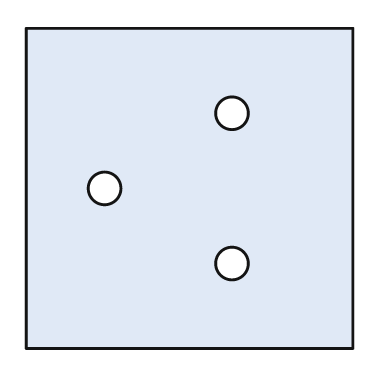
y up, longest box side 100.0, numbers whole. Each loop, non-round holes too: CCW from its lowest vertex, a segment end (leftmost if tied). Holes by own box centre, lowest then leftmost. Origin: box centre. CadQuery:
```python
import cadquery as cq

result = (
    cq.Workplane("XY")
    .moveTo(-50.0, -49.0)
    .lineTo(50.0, -49.0)
    .lineTo(50.0, 49.0)
    .lineTo(-50.0, 49.0)
    .close()
    .moveTo(13.0, -23.0)
    .circle(5.0)
    .moveTo(-26.0, 0.0)
    .circle(5.0)
    .moveTo(13.0, 23.0)
    .circle(5.0)
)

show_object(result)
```